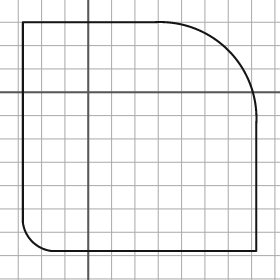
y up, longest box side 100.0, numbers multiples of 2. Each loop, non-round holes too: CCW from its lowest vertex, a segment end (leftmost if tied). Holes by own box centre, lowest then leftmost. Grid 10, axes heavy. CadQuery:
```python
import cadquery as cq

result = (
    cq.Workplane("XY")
    .moveTo(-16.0, -68.0)
    .lineTo(72.0, -68.0)
    .lineTo(72.0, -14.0)
    .threePointArc((60.0, 18.0), (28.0, 30.0))
    .lineTo(-28.0, 30.0)
    .lineTo(-28.0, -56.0)
    .threePointArc((-24.0, -64.0), (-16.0, -68.0))
    .close()
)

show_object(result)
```